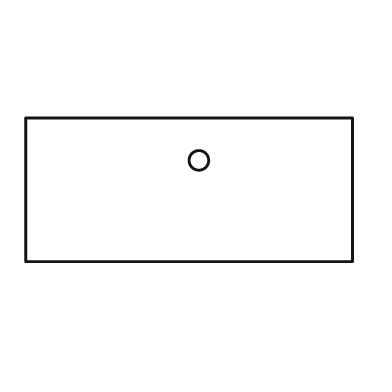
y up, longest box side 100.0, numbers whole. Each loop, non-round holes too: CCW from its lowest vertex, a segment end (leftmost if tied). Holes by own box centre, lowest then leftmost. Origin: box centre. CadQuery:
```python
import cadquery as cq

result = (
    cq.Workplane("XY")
    .moveTo(-50.0, -22.0)
    .lineTo(50.0, -22.0)
    .lineTo(50.0, 22.0)
    .lineTo(-50.0, 22.0)
    .close()
    .moveTo(3.0, 9.0)
    .circle(3.0)
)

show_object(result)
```